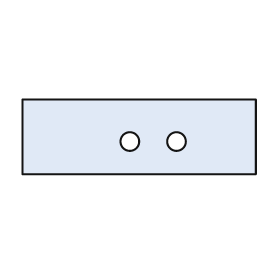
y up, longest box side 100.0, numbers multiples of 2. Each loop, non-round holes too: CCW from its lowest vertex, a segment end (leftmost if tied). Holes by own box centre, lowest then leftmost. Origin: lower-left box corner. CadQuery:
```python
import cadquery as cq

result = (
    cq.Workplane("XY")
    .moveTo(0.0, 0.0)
    .lineTo(100.0, 0.0)
    .lineTo(100.0, 32.0)
    .lineTo(0.0, 32.0)
    .close()
    .moveTo(46.0, 14.0)
    .circle(4.0)
    .moveTo(66.0, 14.0)
    .circle(4.0)
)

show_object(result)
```